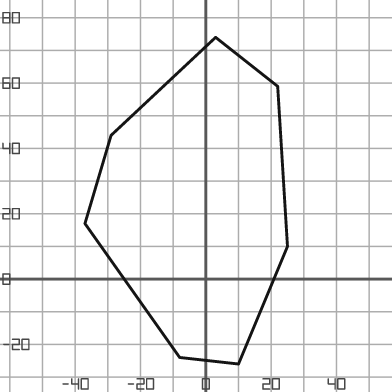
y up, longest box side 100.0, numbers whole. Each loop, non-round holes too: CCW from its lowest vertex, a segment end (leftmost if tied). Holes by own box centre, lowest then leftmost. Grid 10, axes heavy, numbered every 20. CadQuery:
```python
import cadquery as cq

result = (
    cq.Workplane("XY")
    .moveTo(10.0, -26.0)
    .lineTo(25.0, 10.0)
    .lineTo(22.0, 59.0)
    .lineTo(3.0, 74.0)
    .lineTo(-29.0, 44.0)
    .lineTo(-37.0, 17.0)
    .lineTo(-8.0, -24.0)
    .close()
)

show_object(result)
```